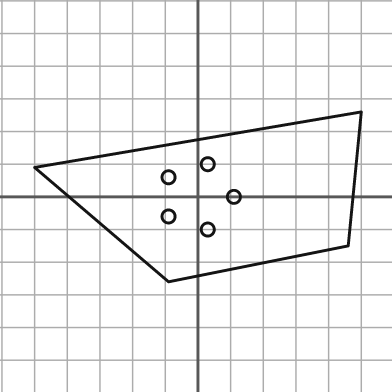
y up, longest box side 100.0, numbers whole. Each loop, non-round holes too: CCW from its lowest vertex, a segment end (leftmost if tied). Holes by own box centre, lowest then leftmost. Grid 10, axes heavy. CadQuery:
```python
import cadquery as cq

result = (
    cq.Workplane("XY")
    .moveTo(-9.0, -26.0)
    .lineTo(46.0, -15.0)
    .lineTo(50.0, 26.0)
    .lineTo(-50.0, 9.0)
    .close()
    .moveTo(3.0, -10.0)
    .circle(2.0)
    .moveTo(-9.0, -6.0)
    .circle(2.0)
    .moveTo(11.0, 0.0)
    .circle(2.0)
    .moveTo(-9.0, 6.0)
    .circle(2.0)
    .moveTo(3.0, 10.0)
    .circle(2.0)
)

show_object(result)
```